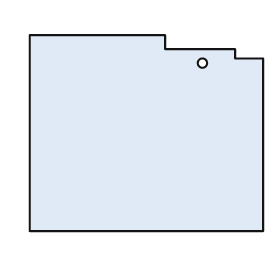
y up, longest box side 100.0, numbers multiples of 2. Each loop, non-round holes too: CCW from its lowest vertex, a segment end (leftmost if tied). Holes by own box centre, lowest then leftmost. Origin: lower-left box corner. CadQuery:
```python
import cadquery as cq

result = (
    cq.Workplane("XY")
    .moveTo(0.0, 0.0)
    .lineTo(100.0, 0.0)
    .lineTo(100.0, 74.0)
    .lineTo(88.0, 74.0)
    .lineTo(88.0, 78.0)
    .lineTo(58.0, 78.0)
    .lineTo(58.0, 84.0)
    .lineTo(0.0, 84.0)
    .close()
    .moveTo(74.0, 72.0)
    .circle(2.0)
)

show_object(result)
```